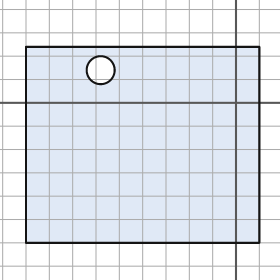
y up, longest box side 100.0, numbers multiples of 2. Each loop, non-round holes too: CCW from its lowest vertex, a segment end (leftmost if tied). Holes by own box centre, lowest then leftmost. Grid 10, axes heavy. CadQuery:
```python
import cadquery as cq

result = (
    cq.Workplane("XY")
    .moveTo(-90.0, -60.0)
    .lineTo(10.0, -60.0)
    .lineTo(10.0, 24.0)
    .lineTo(-90.0, 24.0)
    .close()
    .moveTo(-58.0, 14.0)
    .circle(6.0)
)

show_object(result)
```